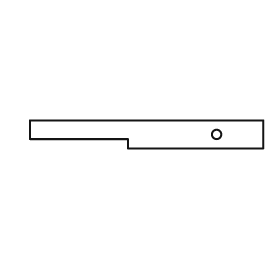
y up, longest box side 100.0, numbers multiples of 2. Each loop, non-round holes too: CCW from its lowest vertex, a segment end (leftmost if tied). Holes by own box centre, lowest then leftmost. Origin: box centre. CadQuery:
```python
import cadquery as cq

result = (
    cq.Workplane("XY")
    .moveTo(-8.0, -6.0)
    .lineTo(50.0, -6.0)
    .lineTo(50.0, 6.0)
    .lineTo(-50.0, 6.0)
    .lineTo(-50.0, -2.0)
    .lineTo(-8.0, -2.0)
    .close()
    .moveTo(30.0, 0.0)
    .circle(2.0)
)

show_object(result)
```